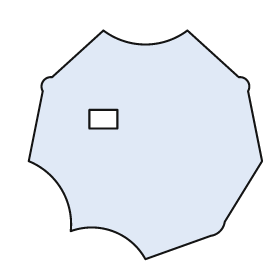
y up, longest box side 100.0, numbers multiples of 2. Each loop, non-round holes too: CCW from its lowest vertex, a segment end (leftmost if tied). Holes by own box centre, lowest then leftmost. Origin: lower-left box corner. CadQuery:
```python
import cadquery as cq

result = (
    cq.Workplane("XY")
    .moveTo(50.0, 0.0)
    .lineTo(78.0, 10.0)
    .threePointArc((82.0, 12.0), (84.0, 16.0))
    .lineTo(100.0, 42.0)
    .lineTo(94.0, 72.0)
    .threePointArc((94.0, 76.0), (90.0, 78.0))
    .lineTo(68.0, 98.0)
    .threePointArc((50.0, 92.0), (32.0, 98.0))
    .lineTo(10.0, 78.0)
    .threePointArc((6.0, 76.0), (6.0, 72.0))
    .lineTo(0.0, 42.0)
    .threePointArc((14.0, 30.0), (18.0, 12.0))
    .threePointArc((36.0, 12.0), (50.0, 0.0))
    .close()
    .moveTo(26.0, 56.0)
    .lineTo(38.0, 56.0)
    .lineTo(38.0, 64.0)
    .lineTo(26.0, 64.0)
    .close()
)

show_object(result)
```